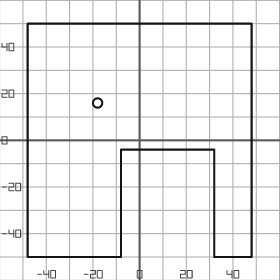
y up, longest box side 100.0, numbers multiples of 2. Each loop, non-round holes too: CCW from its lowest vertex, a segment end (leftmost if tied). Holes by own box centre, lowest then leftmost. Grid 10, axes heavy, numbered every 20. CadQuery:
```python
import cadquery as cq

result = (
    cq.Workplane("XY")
    .moveTo(-48.0, -50.0)
    .lineTo(-8.0, -50.0)
    .lineTo(-8.0, -4.0)
    .lineTo(32.0, -4.0)
    .lineTo(32.0, -50.0)
    .lineTo(48.0, -50.0)
    .lineTo(48.0, 50.0)
    .lineTo(-48.0, 50.0)
    .close()
    .moveTo(-18.0, 16.0)
    .circle(2.0)
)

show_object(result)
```